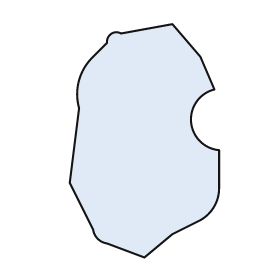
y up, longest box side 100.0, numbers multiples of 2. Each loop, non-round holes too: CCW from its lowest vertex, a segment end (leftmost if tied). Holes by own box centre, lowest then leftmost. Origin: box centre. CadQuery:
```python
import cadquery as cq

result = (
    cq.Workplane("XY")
    .moveTo(0.0, -50.0)
    .lineTo(12.0, -40.0)
    .lineTo(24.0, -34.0)
    .threePointArc((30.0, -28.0), (32.0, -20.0))
    .lineTo(32.0, -4.0)
    .threePointArc((20.0, 8.0), (30.0, 22.0))
    .lineTo(24.0, 36.0)
    .lineTo(12.0, 50.0)
    .lineTo(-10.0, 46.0)
    .threePointArc((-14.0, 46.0), (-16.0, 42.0))
    .lineTo(-22.0, 36.0)
    .threePointArc((-28.0, 26.0), (-28.0, 14.0))
    .lineTo(-32.0, -18.0)
    .lineTo(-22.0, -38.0)
    .threePointArc((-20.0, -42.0), (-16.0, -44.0))
    .close()
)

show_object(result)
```